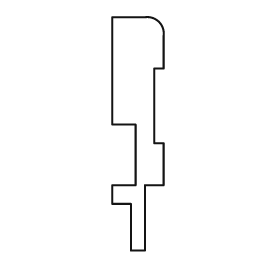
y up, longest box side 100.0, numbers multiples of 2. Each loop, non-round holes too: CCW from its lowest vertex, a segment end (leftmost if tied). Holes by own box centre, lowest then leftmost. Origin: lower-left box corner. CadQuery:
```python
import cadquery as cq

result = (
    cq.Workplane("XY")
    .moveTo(8.0, 0.0)
    .lineTo(14.0, 0.0)
    .lineTo(14.0, 28.0)
    .lineTo(22.0, 28.0)
    .lineTo(22.0, 46.0)
    .lineTo(18.0, 46.0)
    .lineTo(18.0, 78.0)
    .lineTo(22.0, 78.0)
    .lineTo(22.0, 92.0)
    .threePointArc((20.0, 98.0), (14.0, 100.0))
    .lineTo(0.0, 100.0)
    .lineTo(0.0, 54.0)
    .lineTo(10.0, 54.0)
    .lineTo(10.0, 28.0)
    .lineTo(0.0, 28.0)
    .lineTo(0.0, 20.0)
    .lineTo(8.0, 20.0)
    .close()
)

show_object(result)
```